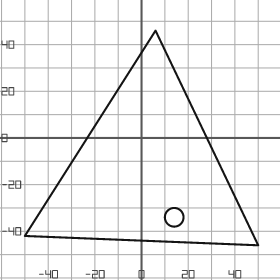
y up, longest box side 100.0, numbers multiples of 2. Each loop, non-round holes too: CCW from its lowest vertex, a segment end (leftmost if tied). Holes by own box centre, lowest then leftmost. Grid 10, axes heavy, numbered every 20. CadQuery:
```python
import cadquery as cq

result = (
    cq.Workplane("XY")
    .moveTo(50.0, -46.0)
    .lineTo(6.0, 46.0)
    .lineTo(-50.0, -42.0)
    .close()
    .moveTo(14.0, -34.0)
    .circle(4.0)
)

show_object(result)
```